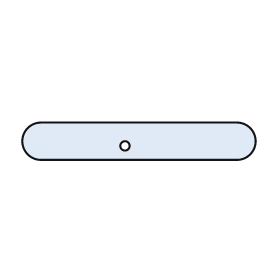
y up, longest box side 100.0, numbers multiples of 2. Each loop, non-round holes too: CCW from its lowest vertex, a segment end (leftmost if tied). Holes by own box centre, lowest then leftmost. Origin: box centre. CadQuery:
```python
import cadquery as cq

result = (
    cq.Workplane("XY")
    .moveTo(-42.0, -8.0)
    .lineTo(42.0, -8.0)
    .threePointArc((50.0, 0.0), (42.0, 8.0))
    .lineTo(-42.0, 8.0)
    .threePointArc((-50.0, 0.0), (-42.0, -8.0))
    .close()
    .moveTo(-6.0, -2.0)
    .circle(2.0)
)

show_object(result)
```